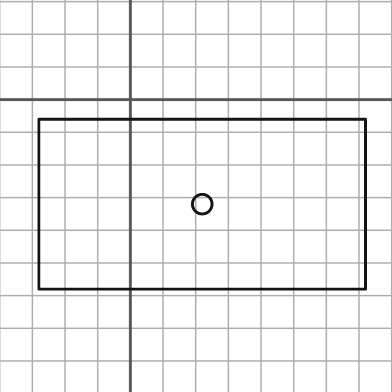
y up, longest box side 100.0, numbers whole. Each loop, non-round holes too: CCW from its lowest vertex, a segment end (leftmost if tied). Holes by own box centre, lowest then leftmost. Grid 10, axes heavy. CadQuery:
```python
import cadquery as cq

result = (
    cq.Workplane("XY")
    .moveTo(-28.0, -58.0)
    .lineTo(72.0, -58.0)
    .lineTo(72.0, -6.0)
    .lineTo(-28.0, -6.0)
    .close()
    .moveTo(22.0, -32.0)
    .circle(3.0)
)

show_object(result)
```